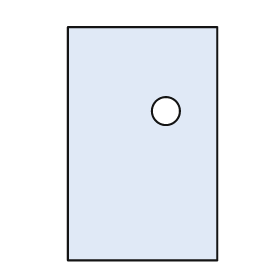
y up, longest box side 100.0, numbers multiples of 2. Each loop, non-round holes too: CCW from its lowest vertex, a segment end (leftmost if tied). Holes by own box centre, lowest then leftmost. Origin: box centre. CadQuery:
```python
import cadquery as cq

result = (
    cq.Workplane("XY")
    .moveTo(-32.0, -50.0)
    .lineTo(32.0, -50.0)
    .lineTo(32.0, 50.0)
    .lineTo(-32.0, 50.0)
    .close()
    .moveTo(10.0, 14.0)
    .circle(6.0)
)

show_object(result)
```